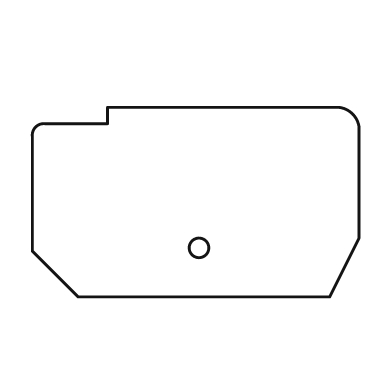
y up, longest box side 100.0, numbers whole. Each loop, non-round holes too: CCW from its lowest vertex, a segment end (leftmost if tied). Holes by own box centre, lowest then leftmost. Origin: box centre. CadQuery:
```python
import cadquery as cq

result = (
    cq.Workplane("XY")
    .moveTo(-36.0, -29.0)
    .lineTo(41.0, -29.0)
    .lineTo(50.0, -11.0)
    .lineTo(50.0, 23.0)
    .threePointArc((48.0, 27.0), (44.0, 29.0))
    .lineTo(-27.0, 29.0)
    .lineTo(-27.0, 24.0)
    .lineTo(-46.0, 24.0)
    .threePointArc((-49.0, 23.0), (-50.0, 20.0))
    .lineTo(-50.0, -15.0)
    .close()
    .moveTo(1.0, -14.0)
    .circle(3.0)
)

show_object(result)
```